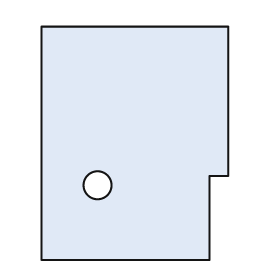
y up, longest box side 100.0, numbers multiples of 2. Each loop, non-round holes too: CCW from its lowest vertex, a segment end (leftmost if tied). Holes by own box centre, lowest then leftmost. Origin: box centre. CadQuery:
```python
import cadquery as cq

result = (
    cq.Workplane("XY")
    .moveTo(-40.0, -50.0)
    .lineTo(32.0, -50.0)
    .lineTo(32.0, -14.0)
    .lineTo(40.0, -14.0)
    .lineTo(40.0, 50.0)
    .lineTo(-40.0, 50.0)
    .close()
    .moveTo(-16.0, -18.0)
    .circle(6.0)
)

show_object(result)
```